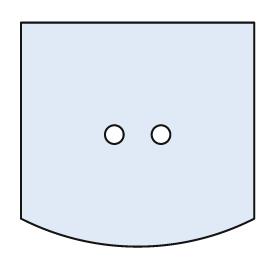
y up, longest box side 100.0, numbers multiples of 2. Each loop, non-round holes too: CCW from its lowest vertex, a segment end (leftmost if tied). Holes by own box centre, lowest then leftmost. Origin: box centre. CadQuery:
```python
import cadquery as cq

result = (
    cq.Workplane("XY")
    .moveTo(-50.0, -36.0)
    .threePointArc((0.0, -48.0), (50.0, -36.0))
    .lineTo(50.0, 48.0)
    .lineTo(-50.0, 48.0)
    .close()
    .moveTo(-10.0, 0.0)
    .circle(4.0)
    .moveTo(10.0, 0.0)
    .circle(4.0)
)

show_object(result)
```